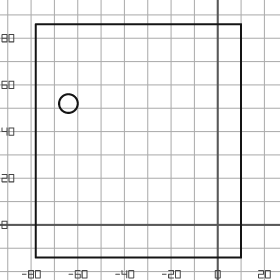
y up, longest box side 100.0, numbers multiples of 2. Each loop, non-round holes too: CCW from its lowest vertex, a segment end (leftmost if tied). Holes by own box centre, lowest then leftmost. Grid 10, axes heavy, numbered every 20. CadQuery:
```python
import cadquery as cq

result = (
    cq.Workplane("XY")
    .moveTo(-78.0, -14.0)
    .lineTo(10.0, -14.0)
    .lineTo(10.0, 86.0)
    .lineTo(-78.0, 86.0)
    .close()
    .moveTo(-64.0, 52.0)
    .circle(4.0)
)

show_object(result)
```